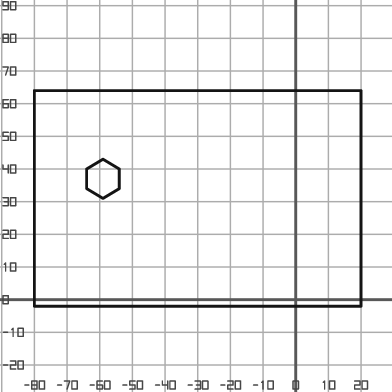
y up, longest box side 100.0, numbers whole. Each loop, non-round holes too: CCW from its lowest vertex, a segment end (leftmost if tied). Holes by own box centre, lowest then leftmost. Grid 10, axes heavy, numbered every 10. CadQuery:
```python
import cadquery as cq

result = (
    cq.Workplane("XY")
    .moveTo(-80.0, -2.0)
    .lineTo(20.0, -2.0)
    .lineTo(20.0, 64.0)
    .lineTo(-80.0, 64.0)
    .close()
    .moveTo(-59.0, 31.0)
    .lineTo(-54.0, 34.0)
    .lineTo(-54.0, 40.0)
    .lineTo(-59.0, 43.0)
    .lineTo(-64.0, 40.0)
    .lineTo(-64.0, 34.0)
    .close()
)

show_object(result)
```